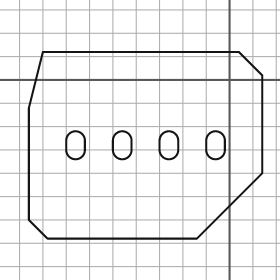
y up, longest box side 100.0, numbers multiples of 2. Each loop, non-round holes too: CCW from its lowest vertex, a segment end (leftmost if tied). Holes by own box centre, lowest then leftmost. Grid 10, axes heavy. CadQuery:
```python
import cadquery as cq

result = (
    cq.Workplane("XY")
    .moveTo(-78.0, -68.0)
    .lineTo(-14.0, -68.0)
    .lineTo(14.0, -40.0)
    .lineTo(14.0, 2.0)
    .lineTo(4.0, 12.0)
    .lineTo(-80.0, 12.0)
    .lineTo(-86.0, -12.0)
    .lineTo(-86.0, -60.0)
    .close()
    .moveTo(-70.0, -30.0)
    .threePointArc((-66.0, -34.0), (-62.0, -30.0))
    .lineTo(-62.0, -26.0)
    .threePointArc((-66.0, -22.0), (-70.0, -26.0))
    .close()
    .moveTo(-50.0, -30.0)
    .threePointArc((-46.0, -34.0), (-42.0, -30.0))
    .lineTo(-42.0, -26.0)
    .threePointArc((-46.0, -22.0), (-50.0, -26.0))
    .close()
    .moveTo(-30.0, -30.0)
    .threePointArc((-26.0, -34.0), (-22.0, -30.0))
    .lineTo(-22.0, -26.0)
    .threePointArc((-26.0, -22.0), (-30.0, -26.0))
    .close()
    .moveTo(-10.0, -30.0)
    .threePointArc((-6.0, -34.0), (-2.0, -30.0))
    .lineTo(-2.0, -26.0)
    .threePointArc((-6.0, -22.0), (-10.0, -26.0))
    .close()
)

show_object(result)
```